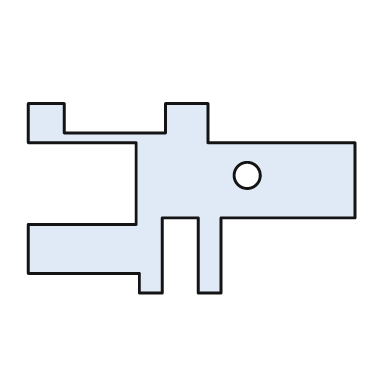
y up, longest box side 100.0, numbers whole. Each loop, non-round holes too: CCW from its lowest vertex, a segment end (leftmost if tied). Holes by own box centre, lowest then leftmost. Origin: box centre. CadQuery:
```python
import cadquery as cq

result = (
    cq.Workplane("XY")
    .moveTo(-16.0, -29.0)
    .lineTo(-9.0, -29.0)
    .lineTo(-9.0, -6.0)
    .lineTo(2.0, -6.0)
    .lineTo(2.0, -29.0)
    .lineTo(9.0, -29.0)
    .lineTo(9.0, -6.0)
    .lineTo(50.0, -6.0)
    .lineTo(50.0, 17.0)
    .lineTo(5.0, 17.0)
    .lineTo(5.0, 29.0)
    .lineTo(-8.0, 29.0)
    .lineTo(-8.0, 20.0)
    .lineTo(-39.0, 20.0)
    .lineTo(-39.0, 29.0)
    .lineTo(-50.0, 29.0)
    .lineTo(-50.0, 17.0)
    .lineTo(-17.0, 17.0)
    .lineTo(-17.0, -8.0)
    .lineTo(-50.0, -8.0)
    .lineTo(-50.0, -23.0)
    .lineTo(-16.0, -23.0)
    .close()
    .moveTo(17.0, 7.0)
    .circle(4.0)
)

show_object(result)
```